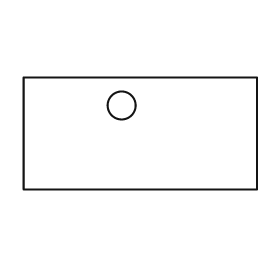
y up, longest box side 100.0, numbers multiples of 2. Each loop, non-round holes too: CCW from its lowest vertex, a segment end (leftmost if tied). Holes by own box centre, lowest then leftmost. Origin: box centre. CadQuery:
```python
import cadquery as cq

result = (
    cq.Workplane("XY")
    .moveTo(-50.0, -24.0)
    .lineTo(50.0, -24.0)
    .lineTo(50.0, 24.0)
    .lineTo(-50.0, 24.0)
    .close()
    .moveTo(-8.0, 12.0)
    .circle(6.0)
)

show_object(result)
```